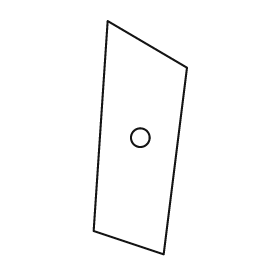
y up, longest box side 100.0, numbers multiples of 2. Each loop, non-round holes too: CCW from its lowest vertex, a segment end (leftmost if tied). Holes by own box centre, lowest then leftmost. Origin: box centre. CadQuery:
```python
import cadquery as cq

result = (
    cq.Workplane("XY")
    .moveTo(10.0, -50.0)
    .lineTo(20.0, 30.0)
    .lineTo(-14.0, 50.0)
    .lineTo(-20.0, -40.0)
    .close()
    .moveTo(0.0, 0.0)
    .circle(4.0)
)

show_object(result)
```